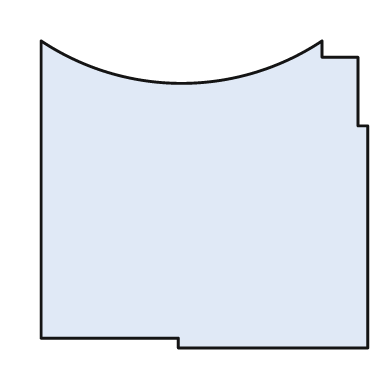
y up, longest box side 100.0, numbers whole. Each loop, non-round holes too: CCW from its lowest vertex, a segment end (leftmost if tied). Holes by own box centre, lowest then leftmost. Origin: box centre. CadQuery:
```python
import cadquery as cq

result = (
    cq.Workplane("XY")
    .moveTo(-8.0, -47.0)
    .lineTo(50.0, -47.0)
    .lineTo(50.0, 21.0)
    .lineTo(47.0, 21.0)
    .lineTo(47.0, 42.0)
    .lineTo(36.0, 42.0)
    .lineTo(36.0, 47.0)
    .threePointArc((-7.0, 34.0), (-50.0, 47.0))
    .lineTo(-50.0, -44.0)
    .lineTo(-8.0, -44.0)
    .close()
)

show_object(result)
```